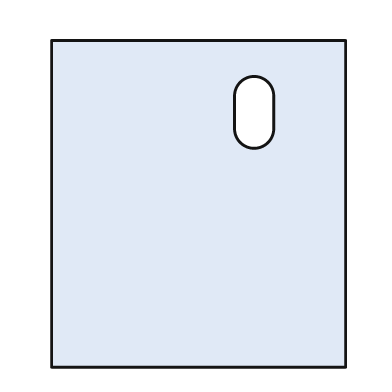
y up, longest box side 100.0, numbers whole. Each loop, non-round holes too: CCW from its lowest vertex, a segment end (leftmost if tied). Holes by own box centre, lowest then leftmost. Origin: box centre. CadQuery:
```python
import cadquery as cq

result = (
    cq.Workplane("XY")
    .moveTo(-45.0, -50.0)
    .lineTo(45.0, -50.0)
    .lineTo(45.0, 50.0)
    .lineTo(-45.0, 50.0)
    .close()
    .moveTo(11.0, 23.0)
    .threePointArc((17.0, 17.0), (23.0, 23.0))
    .lineTo(23.0, 33.0)
    .threePointArc((17.0, 39.0), (11.0, 33.0))
    .close()
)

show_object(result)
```